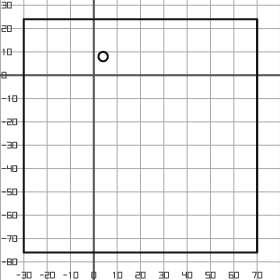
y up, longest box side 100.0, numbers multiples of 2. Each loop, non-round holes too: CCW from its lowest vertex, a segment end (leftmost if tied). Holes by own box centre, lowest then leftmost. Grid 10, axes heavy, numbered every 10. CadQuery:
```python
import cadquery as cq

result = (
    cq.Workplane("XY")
    .moveTo(-30.0, -76.0)
    .lineTo(70.0, -76.0)
    .lineTo(70.0, 24.0)
    .lineTo(-30.0, 24.0)
    .close()
    .moveTo(4.0, 8.0)
    .circle(2.0)
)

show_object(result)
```